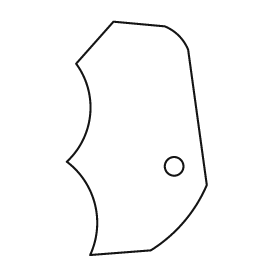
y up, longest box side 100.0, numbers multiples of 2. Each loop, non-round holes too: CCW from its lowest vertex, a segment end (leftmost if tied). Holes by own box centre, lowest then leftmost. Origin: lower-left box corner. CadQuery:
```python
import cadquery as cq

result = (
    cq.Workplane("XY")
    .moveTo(10.0, 0.0)
    .lineTo(36.0, 2.0)
    .threePointArc((50.0, 14.0), (60.0, 30.0))
    .lineTo(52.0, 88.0)
    .threePointArc((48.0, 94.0), (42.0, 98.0))
    .lineTo(20.0, 100.0)
    .lineTo(4.0, 82.0)
    .threePointArc((10.0, 60.0), (0.0, 40.0))
    .threePointArc((12.0, 22.0), (10.0, 0.0))
    .close()
    .moveTo(46.0, 38.0)
    .circle(4.0)
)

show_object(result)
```